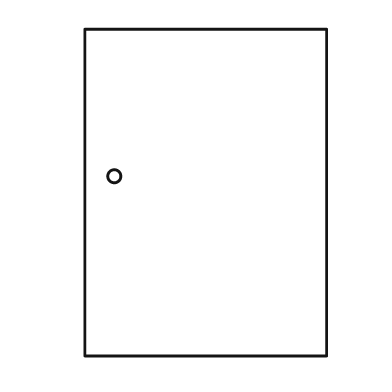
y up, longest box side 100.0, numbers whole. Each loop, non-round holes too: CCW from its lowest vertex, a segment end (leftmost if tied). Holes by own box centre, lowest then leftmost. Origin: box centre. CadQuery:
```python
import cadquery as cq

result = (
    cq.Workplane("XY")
    .moveTo(-37.0, -50.0)
    .lineTo(37.0, -50.0)
    .lineTo(37.0, 50.0)
    .lineTo(-37.0, 50.0)
    .close()
    .moveTo(-28.0, 5.0)
    .circle(2.0)
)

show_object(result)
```